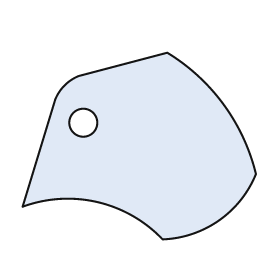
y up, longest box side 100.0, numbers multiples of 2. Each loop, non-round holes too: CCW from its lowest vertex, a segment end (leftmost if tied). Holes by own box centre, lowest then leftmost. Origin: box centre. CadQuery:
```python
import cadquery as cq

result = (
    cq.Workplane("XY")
    .moveTo(10.0, -40.0)
    .threePointArc((34.0, -32.0), (50.0, -12.0))
    .threePointArc((36.0, 18.0), (12.0, 40.0))
    .lineTo(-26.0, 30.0)
    .threePointArc((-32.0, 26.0), (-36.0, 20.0))
    .lineTo(-50.0, -26.0)
    .threePointArc((-18.0, -24.0), (10.0, -40.0))
    .close()
    .moveTo(-24.0, 10.0)
    .circle(6.0)
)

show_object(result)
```